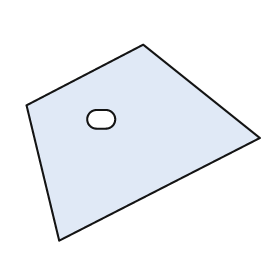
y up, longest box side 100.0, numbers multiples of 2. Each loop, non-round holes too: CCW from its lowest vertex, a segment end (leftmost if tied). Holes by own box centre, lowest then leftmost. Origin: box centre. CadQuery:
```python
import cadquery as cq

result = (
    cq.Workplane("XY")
    .moveTo(-36.0, -42.0)
    .lineTo(50.0, 2.0)
    .lineTo(0.0, 42.0)
    .lineTo(-50.0, 16.0)
    .close()
    .moveTo(-20.0, 6.0)
    .lineTo(-16.0, 6.0)
    .threePointArc((-12.0, 10.0), (-16.0, 14.0))
    .lineTo(-20.0, 14.0)
    .threePointArc((-24.0, 10.0), (-20.0, 6.0))
    .close()
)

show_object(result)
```